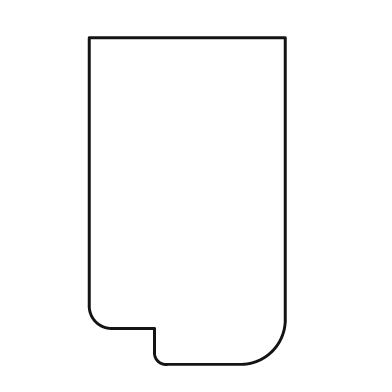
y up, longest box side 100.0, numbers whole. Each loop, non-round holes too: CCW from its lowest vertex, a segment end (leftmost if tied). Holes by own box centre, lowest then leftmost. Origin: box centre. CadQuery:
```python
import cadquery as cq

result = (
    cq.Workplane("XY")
    .moveTo(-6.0, -50.0)
    .lineTo(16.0, -50.0)
    .threePointArc((26.0, -46.0), (30.0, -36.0))
    .lineTo(30.0, 50.0)
    .lineTo(-30.0, 50.0)
    .lineTo(-30.0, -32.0)
    .threePointArc((-28.0, -37.0), (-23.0, -39.0))
    .lineTo(-10.0, -39.0)
    .lineTo(-10.0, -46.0)
    .threePointArc((-9.0, -49.0), (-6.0, -50.0))
    .close()
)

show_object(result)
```